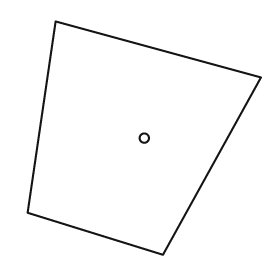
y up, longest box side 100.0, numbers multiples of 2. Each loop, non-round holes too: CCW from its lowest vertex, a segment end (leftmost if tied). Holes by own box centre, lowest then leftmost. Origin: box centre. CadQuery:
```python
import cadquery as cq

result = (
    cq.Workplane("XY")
    .moveTo(8.0, -50.0)
    .lineTo(50.0, 26.0)
    .lineTo(-38.0, 50.0)
    .lineTo(-50.0, -32.0)
    .close()
    .moveTo(0.0, 0.0)
    .circle(2.0)
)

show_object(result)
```